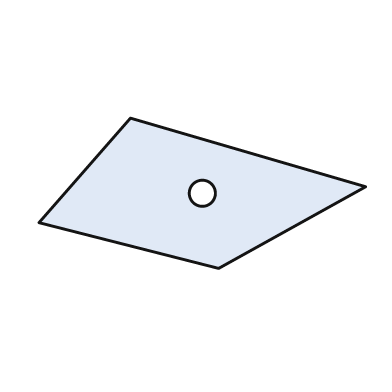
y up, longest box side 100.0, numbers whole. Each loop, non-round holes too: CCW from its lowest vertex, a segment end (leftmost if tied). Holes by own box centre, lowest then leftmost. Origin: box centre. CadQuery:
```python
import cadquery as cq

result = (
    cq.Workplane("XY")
    .moveTo(5.0, -23.0)
    .lineTo(50.0, 2.0)
    .lineTo(-22.0, 23.0)
    .lineTo(-50.0, -9.0)
    .close()
    .moveTo(0.0, 0.0)
    .circle(4.0)
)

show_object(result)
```